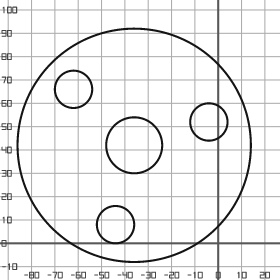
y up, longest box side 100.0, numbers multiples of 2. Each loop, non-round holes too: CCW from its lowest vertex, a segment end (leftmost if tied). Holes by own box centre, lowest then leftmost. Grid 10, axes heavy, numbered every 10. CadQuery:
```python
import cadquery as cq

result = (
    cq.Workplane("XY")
    .moveTo(-36.0, 42.0)
    .circle(50.0)
    .moveTo(-44.0, 8.0)
    .circle(8.0)
    .moveTo(-36.0, 42.0)
    .circle(12.0)
    .moveTo(-4.0, 52.0)
    .circle(8.0)
    .moveTo(-62.0, 66.0)
    .circle(8.0)
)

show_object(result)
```